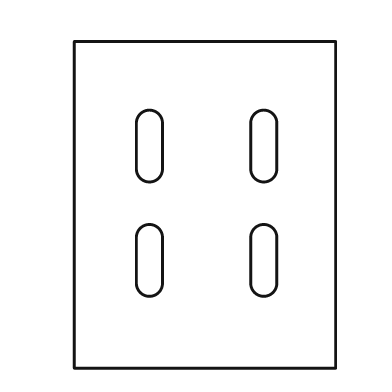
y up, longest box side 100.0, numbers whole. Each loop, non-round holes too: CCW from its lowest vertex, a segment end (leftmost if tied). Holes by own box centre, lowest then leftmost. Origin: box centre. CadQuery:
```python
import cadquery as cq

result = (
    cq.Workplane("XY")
    .moveTo(-40.0, -50.0)
    .lineTo(40.0, -50.0)
    .lineTo(40.0, 50.0)
    .lineTo(-40.0, 50.0)
    .close()
    .moveTo(-21.0, -24.0)
    .threePointArc((-17.0, -28.0), (-13.0, -24.0))
    .lineTo(-13.0, -10.0)
    .threePointArc((-17.0, -6.0), (-21.0, -10.0))
    .close()
    .moveTo(14.0, -24.0)
    .threePointArc((18.0, -28.0), (22.0, -24.0))
    .lineTo(22.0, -10.0)
    .threePointArc((18.0, -6.0), (14.0, -10.0))
    .close()
    .moveTo(-21.0, 11.0)
    .threePointArc((-17.0, 7.0), (-13.0, 11.0))
    .lineTo(-13.0, 25.0)
    .threePointArc((-17.0, 29.0), (-21.0, 25.0))
    .close()
    .moveTo(14.0, 11.0)
    .threePointArc((18.0, 7.0), (22.0, 11.0))
    .lineTo(22.0, 25.0)
    .threePointArc((18.0, 29.0), (14.0, 25.0))
    .close()
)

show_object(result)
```